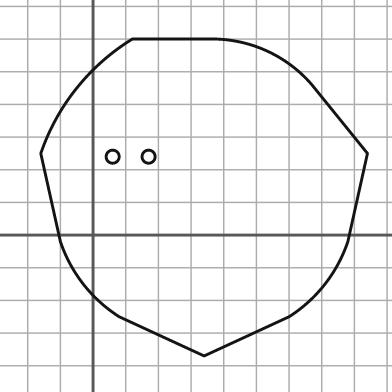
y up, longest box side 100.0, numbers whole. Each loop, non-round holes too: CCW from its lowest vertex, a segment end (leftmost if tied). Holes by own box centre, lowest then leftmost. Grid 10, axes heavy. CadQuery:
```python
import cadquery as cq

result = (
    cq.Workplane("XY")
    .moveTo(34.0, -37.0)
    .lineTo(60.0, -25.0)
    .threePointArc((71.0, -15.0), (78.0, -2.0))
    .lineTo(84.0, 25.0)
    .lineTo(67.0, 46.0)
    .threePointArc((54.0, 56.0), (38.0, 60.0))
    .lineTo(12.0, 60.0)
    .threePointArc((-5.0, 45.0), (-16.0, 25.0))
    .lineTo(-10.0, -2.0)
    .threePointArc((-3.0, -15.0), (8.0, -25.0))
    .close()
    .moveTo(6.0, 24.0)
    .circle(2.0)
    .moveTo(17.0, 24.0)
    .circle(2.0)
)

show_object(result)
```